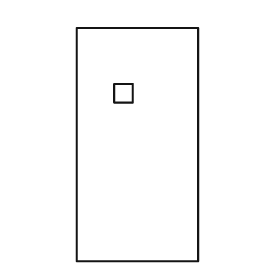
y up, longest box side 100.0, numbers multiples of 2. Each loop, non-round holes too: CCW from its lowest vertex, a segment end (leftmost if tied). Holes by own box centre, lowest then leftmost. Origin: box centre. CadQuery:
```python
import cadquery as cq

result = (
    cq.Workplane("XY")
    .moveTo(-26.0, -50.0)
    .lineTo(26.0, -50.0)
    .lineTo(26.0, 50.0)
    .lineTo(-26.0, 50.0)
    .close()
    .moveTo(-10.0, 18.0)
    .lineTo(-2.0, 18.0)
    .lineTo(-2.0, 26.0)
    .lineTo(-10.0, 26.0)
    .close()
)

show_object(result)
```